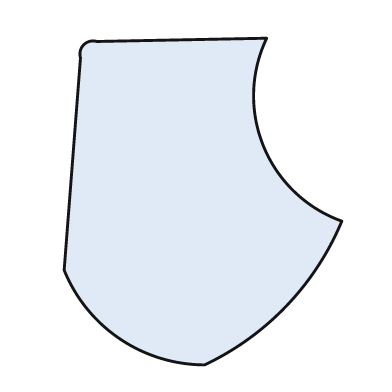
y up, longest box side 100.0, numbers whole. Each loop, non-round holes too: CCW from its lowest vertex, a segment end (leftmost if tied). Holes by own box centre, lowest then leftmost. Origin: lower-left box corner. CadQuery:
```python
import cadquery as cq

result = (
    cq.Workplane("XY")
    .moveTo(43.0, 0.0)
    .threePointArc((68.0, 18.0), (85.0, 44.0))
    .threePointArc((61.0, 67.0), (62.0, 100.0))
    .lineTo(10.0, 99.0)
    .threePointArc((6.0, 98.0), (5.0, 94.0))
    .lineTo(0.0, 29.0)
    .threePointArc((17.0, 8.0), (43.0, 0.0))
    .close()
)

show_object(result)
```